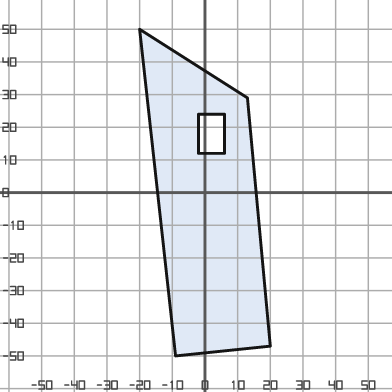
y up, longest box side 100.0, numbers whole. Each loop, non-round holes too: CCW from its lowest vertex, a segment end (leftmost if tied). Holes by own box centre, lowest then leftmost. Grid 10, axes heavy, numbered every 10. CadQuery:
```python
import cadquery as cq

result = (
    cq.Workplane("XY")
    .moveTo(-9.0, -50.0)
    .lineTo(20.0, -47.0)
    .lineTo(13.0, 29.0)
    .lineTo(-20.0, 50.0)
    .close()
    .moveTo(-2.0, 12.0)
    .lineTo(6.0, 12.0)
    .lineTo(6.0, 24.0)
    .lineTo(-2.0, 24.0)
    .close()
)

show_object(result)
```